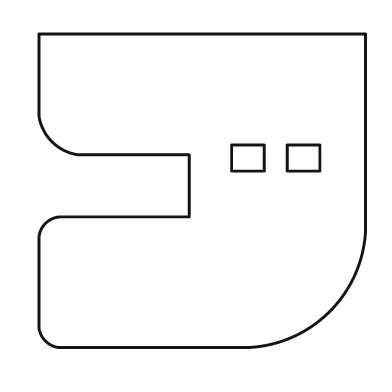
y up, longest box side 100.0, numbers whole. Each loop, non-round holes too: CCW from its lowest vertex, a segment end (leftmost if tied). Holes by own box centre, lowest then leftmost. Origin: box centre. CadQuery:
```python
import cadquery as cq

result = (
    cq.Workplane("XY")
    .moveTo(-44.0, -48.0)
    .lineTo(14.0, -48.0)
    .threePointArc((39.0, -37.0), (50.0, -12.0))
    .lineTo(50.0, 48.0)
    .lineTo(-50.0, 48.0)
    .lineTo(-50.0, 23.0)
    .threePointArc((-46.0, 15.0), (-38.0, 11.0))
    .lineTo(-4.0, 11.0)
    .lineTo(-4.0, -8.0)
    .lineTo(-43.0, -8.0)
    .threePointArc((-48.0, -10.0), (-50.0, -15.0))
    .lineTo(-50.0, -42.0)
    .threePointArc((-48.0, -46.0), (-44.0, -48.0))
    .close()
    .moveTo(9.0, 6.0)
    .lineTo(19.0, 6.0)
    .lineTo(19.0, 14.0)
    .lineTo(9.0, 14.0)
    .close()
    .moveTo(26.0, 6.0)
    .lineTo(36.0, 6.0)
    .lineTo(36.0, 14.0)
    .lineTo(26.0, 14.0)
    .close()
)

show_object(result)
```